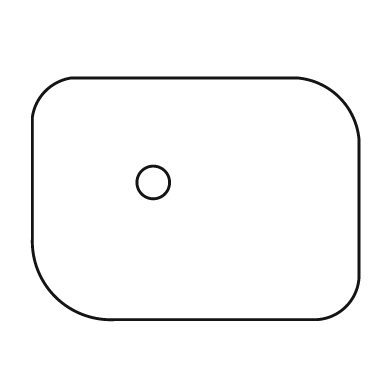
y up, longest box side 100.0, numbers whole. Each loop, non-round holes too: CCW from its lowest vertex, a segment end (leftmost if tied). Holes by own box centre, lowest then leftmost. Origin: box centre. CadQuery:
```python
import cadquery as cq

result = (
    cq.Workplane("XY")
    .moveTo(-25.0, -37.0)
    .lineTo(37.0, -37.0)
    .threePointArc((46.0, -33.0), (50.0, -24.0))
    .lineTo(50.0, 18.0)
    .threePointArc((44.0, 31.0), (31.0, 37.0))
    .lineTo(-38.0, 37.0)
    .threePointArc((-46.0, 33.0), (-50.0, 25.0))
    .lineTo(-50.0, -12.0)
    .threePointArc((-43.0, -30.0), (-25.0, -37.0))
    .close()
    .moveTo(-13.0, 5.0)
    .circle(5.0)
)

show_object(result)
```